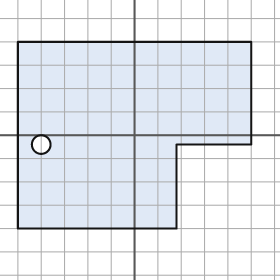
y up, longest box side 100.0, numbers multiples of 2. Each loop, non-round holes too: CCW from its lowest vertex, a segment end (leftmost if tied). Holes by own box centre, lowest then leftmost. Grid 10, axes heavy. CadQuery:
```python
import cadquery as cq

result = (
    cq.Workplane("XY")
    .moveTo(-50.0, -40.0)
    .lineTo(18.0, -40.0)
    .lineTo(18.0, -4.0)
    .lineTo(50.0, -4.0)
    .lineTo(50.0, 40.0)
    .lineTo(-50.0, 40.0)
    .close()
    .moveTo(-40.0, -4.0)
    .circle(4.0)
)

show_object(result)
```